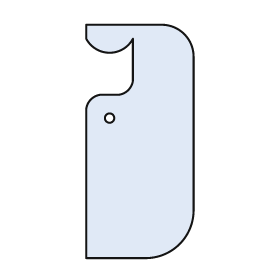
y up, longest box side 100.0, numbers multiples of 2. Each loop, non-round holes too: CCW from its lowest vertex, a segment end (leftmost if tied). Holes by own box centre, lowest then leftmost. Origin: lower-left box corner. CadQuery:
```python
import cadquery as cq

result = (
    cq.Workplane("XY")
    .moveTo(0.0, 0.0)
    .lineTo(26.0, 0.0)
    .threePointArc((40.0, 6.0), (46.0, 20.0))
    .lineTo(46.0, 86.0)
    .threePointArc((42.0, 96.0), (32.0, 100.0))
    .lineTo(0.0, 100.0)
    .lineTo(0.0, 94.0)
    .threePointArc((10.0, 88.0), (20.0, 94.0))
    .lineTo(20.0, 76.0)
    .threePointArc((18.0, 72.0), (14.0, 70.0))
    .lineTo(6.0, 70.0)
    .threePointArc((2.0, 68.0), (0.0, 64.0))
    .close()
    .moveTo(10.0, 60.0)
    .circle(2.0)
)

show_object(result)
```